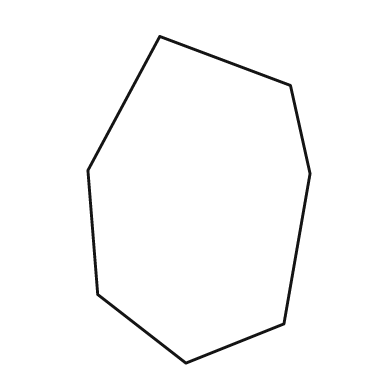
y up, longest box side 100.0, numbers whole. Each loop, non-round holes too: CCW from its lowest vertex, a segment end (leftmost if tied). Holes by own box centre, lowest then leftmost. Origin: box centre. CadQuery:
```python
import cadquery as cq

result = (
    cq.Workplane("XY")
    .moveTo(-4.0, -50.0)
    .lineTo(26.0, -38.0)
    .lineTo(34.0, 8.0)
    .lineTo(28.0, 35.0)
    .lineTo(-12.0, 50.0)
    .lineTo(-34.0, 9.0)
    .lineTo(-31.0, -29.0)
    .close()
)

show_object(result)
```